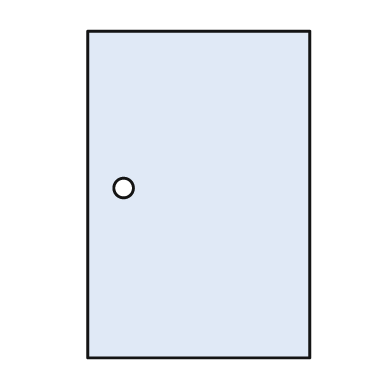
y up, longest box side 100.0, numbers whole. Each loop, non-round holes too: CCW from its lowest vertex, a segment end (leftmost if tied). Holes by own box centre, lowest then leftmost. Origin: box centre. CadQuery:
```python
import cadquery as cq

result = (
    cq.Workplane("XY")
    .moveTo(-34.0, -50.0)
    .lineTo(34.0, -50.0)
    .lineTo(34.0, 50.0)
    .lineTo(-34.0, 50.0)
    .close()
    .moveTo(-23.0, 2.0)
    .circle(3.0)
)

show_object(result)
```